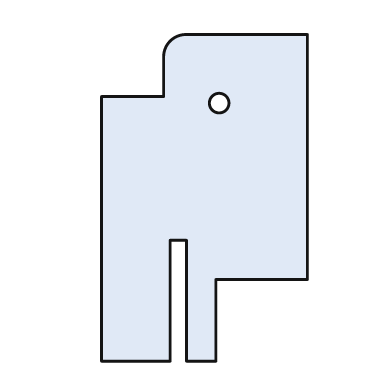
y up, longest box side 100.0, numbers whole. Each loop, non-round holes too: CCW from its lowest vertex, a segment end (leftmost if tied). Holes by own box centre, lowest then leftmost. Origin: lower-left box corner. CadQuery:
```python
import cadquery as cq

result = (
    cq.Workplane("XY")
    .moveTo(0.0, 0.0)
    .lineTo(21.0, 0.0)
    .lineTo(21.0, 37.0)
    .lineTo(26.0, 37.0)
    .lineTo(26.0, 0.0)
    .lineTo(35.0, 0.0)
    .lineTo(35.0, 25.0)
    .lineTo(63.0, 25.0)
    .lineTo(63.0, 100.0)
    .lineTo(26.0, 100.0)
    .threePointArc((21.0, 98.0), (19.0, 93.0))
    .lineTo(19.0, 81.0)
    .lineTo(0.0, 81.0)
    .close()
    .moveTo(36.0, 79.0)
    .circle(3.0)
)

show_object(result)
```